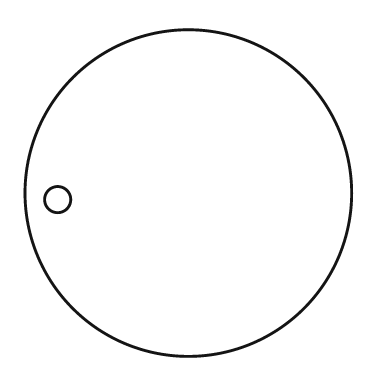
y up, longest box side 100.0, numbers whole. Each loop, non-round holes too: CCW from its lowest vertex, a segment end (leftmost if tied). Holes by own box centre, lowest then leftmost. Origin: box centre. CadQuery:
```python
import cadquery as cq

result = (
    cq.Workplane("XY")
    .moveTo(0.0, 0.0)
    .circle(50.0)
    .moveTo(-40.0, -2.0)
    .circle(4.0)
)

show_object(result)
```